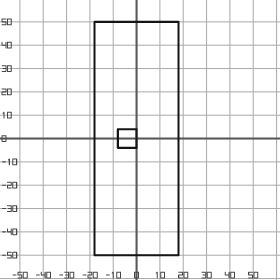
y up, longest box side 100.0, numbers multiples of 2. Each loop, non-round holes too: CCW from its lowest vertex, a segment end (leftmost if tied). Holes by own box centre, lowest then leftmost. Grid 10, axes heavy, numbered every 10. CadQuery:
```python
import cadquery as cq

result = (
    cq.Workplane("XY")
    .moveTo(-18.0, -50.0)
    .lineTo(18.0, -50.0)
    .lineTo(18.0, 50.0)
    .lineTo(-18.0, 50.0)
    .close()
    .moveTo(-8.0, -4.0)
    .lineTo(0.0, -4.0)
    .lineTo(0.0, 4.0)
    .lineTo(-8.0, 4.0)
    .close()
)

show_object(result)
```